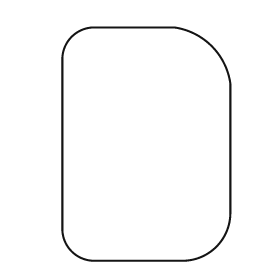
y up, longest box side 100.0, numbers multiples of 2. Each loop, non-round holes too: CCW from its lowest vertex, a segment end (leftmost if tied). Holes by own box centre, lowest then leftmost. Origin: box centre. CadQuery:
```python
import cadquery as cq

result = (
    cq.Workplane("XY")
    .moveTo(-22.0, -50.0)
    .lineTo(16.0, -50.0)
    .threePointArc((30.0, -44.0), (36.0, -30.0))
    .lineTo(36.0, 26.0)
    .threePointArc((28.0, 42.0), (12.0, 50.0))
    .lineTo(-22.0, 50.0)
    .threePointArc((-32.0, 46.0), (-36.0, 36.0))
    .lineTo(-36.0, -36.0)
    .threePointArc((-32.0, -46.0), (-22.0, -50.0))
    .close()
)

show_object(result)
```